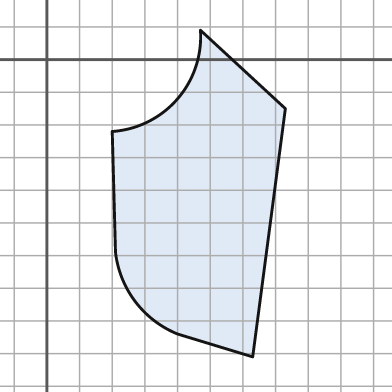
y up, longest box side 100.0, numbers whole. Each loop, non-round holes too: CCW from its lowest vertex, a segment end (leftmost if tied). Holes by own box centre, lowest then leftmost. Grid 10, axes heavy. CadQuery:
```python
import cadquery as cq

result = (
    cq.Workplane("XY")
    .moveTo(63.0, -91.0)
    .lineTo(73.0, -15.0)
    .lineTo(47.0, 9.0)
    .threePointArc((40.0, -12.0), (20.0, -22.0))
    .lineTo(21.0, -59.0)
    .threePointArc((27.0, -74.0), (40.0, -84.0))
    .close()
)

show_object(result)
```